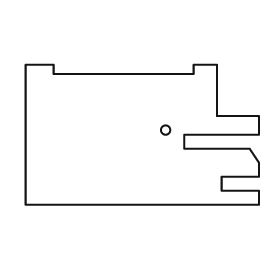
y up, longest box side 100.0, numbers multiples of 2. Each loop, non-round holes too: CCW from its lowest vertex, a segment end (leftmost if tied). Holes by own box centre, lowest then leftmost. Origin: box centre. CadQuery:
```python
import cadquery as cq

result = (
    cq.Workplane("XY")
    .moveTo(-50.0, -30.0)
    .lineTo(50.0, -30.0)
    .lineTo(50.0, -24.0)
    .lineTo(34.0, -24.0)
    .lineTo(34.0, -18.0)
    .lineTo(50.0, -18.0)
    .lineTo(50.0, -12.0)
    .lineTo(46.0, -6.0)
    .lineTo(18.0, -6.0)
    .lineTo(18.0, 0.0)
    .lineTo(50.0, 0.0)
    .lineTo(50.0, 8.0)
    .lineTo(32.0, 8.0)
    .lineTo(32.0, 30.0)
    .lineTo(22.0, 30.0)
    .lineTo(22.0, 26.0)
    .lineTo(-38.0, 26.0)
    .lineTo(-38.0, 30.0)
    .lineTo(-50.0, 30.0)
    .close()
    .moveTo(10.0, 2.0)
    .circle(2.0)
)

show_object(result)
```